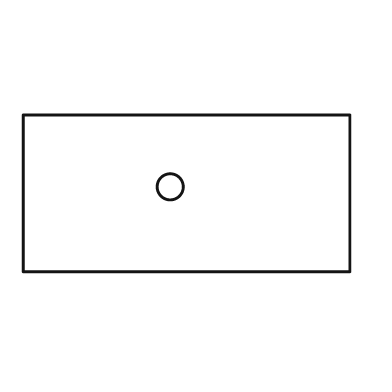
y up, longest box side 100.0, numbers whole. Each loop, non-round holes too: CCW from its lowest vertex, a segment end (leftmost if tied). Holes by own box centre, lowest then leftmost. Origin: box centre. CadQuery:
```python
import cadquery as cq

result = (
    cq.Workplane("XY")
    .moveTo(-50.0, -24.0)
    .lineTo(50.0, -24.0)
    .lineTo(50.0, 24.0)
    .lineTo(-50.0, 24.0)
    .close()
    .moveTo(-5.0, 2.0)
    .circle(4.0)
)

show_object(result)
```